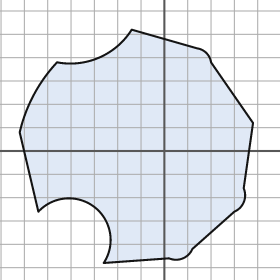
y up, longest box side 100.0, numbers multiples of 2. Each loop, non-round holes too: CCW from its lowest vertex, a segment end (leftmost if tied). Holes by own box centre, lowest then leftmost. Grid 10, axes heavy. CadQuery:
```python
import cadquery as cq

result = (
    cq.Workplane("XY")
    .moveTo(-26.0, -48.0)
    .lineTo(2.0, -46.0)
    .threePointArc((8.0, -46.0), (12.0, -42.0))
    .lineTo(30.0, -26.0)
    .threePointArc((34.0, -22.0), (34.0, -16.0))
    .lineTo(38.0, 12.0)
    .lineTo(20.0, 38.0)
    .threePointArc((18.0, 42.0), (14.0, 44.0))
    .lineTo(-14.0, 52.0)
    .threePointArc((-28.0, 40.0), (-46.0, 38.0))
    .threePointArc((-56.0, 24.0), (-62.0, 8.0))
    .lineTo(-54.0, -26.0)
    .threePointArc((-30.0, -24.0), (-26.0, -48.0))
    .close()
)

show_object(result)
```